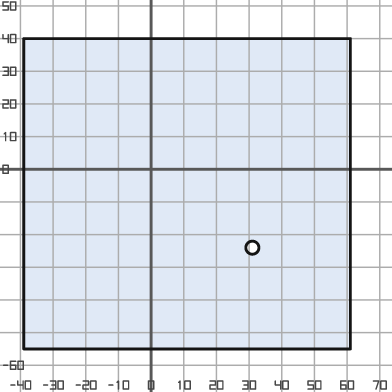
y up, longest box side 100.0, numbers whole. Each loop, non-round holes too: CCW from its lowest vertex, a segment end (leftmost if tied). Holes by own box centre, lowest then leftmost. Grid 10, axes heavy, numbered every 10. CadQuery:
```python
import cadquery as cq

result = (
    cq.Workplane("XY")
    .moveTo(-39.0, -55.0)
    .lineTo(61.0, -55.0)
    .lineTo(61.0, 40.0)
    .lineTo(-39.0, 40.0)
    .close()
    .moveTo(31.0, -24.0)
    .circle(2.0)
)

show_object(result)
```